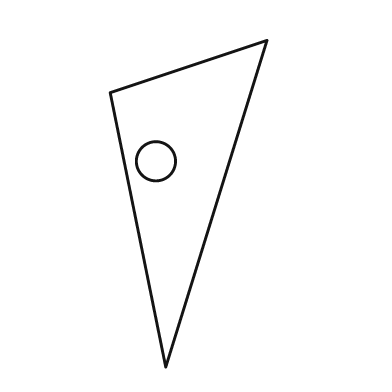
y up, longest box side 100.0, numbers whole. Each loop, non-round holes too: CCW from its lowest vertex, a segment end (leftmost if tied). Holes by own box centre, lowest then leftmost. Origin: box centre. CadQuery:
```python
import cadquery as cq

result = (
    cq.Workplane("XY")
    .moveTo(-7.0, -50.0)
    .lineTo(24.0, 50.0)
    .lineTo(-24.0, 34.0)
    .close()
    .moveTo(-10.0, 13.0)
    .circle(6.0)
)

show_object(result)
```